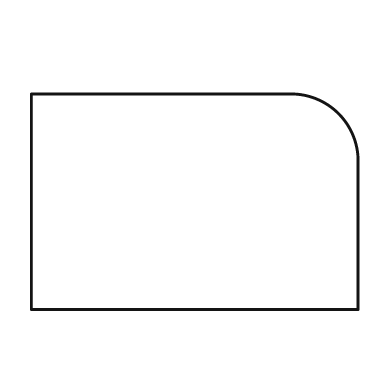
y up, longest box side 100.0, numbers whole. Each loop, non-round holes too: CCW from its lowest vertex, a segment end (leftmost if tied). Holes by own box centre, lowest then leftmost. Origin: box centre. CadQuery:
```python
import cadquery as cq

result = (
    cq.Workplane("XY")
    .moveTo(-50.0, -33.0)
    .lineTo(50.0, -33.0)
    .lineTo(50.0, 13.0)
    .threePointArc((44.0, 27.0), (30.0, 33.0))
    .lineTo(-50.0, 33.0)
    .close()
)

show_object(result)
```